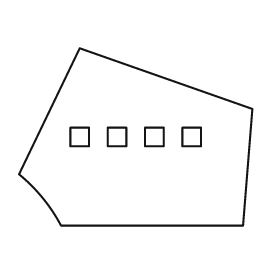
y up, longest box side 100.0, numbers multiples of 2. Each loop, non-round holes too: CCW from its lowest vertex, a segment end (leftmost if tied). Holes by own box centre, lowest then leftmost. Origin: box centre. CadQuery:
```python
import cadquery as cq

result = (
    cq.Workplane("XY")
    .moveTo(-32.0, -38.0)
    .lineTo(46.0, -38.0)
    .lineTo(50.0, 12.0)
    .lineTo(-24.0, 38.0)
    .lineTo(-50.0, -16.0)
    .threePointArc((-40.0, -26.0), (-32.0, -38.0))
    .close()
    .moveTo(-28.0, -4.0)
    .lineTo(-20.0, -4.0)
    .lineTo(-20.0, 4.0)
    .lineTo(-28.0, 4.0)
    .close()
    .moveTo(-12.0, -4.0)
    .lineTo(-4.0, -4.0)
    .lineTo(-4.0, 4.0)
    .lineTo(-12.0, 4.0)
    .close()
    .moveTo(4.0, -4.0)
    .lineTo(12.0, -4.0)
    .lineTo(12.0, 4.0)
    .lineTo(4.0, 4.0)
    .close()
    .moveTo(20.0, -4.0)
    .lineTo(28.0, -4.0)
    .lineTo(28.0, 4.0)
    .lineTo(20.0, 4.0)
    .close()
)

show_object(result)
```